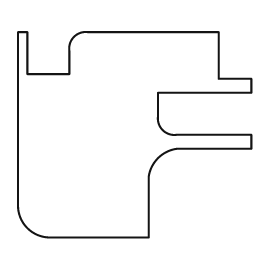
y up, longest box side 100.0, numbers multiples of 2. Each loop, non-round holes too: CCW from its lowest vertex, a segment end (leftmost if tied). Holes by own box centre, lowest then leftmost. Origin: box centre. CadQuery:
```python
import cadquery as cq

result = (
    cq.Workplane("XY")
    .moveTo(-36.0, -44.0)
    .lineTo(6.0, -44.0)
    .lineTo(6.0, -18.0)
    .threePointArc((10.0, -10.0), (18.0, -6.0))
    .lineTo(50.0, -6.0)
    .lineTo(50.0, 0.0)
    .lineTo(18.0, 0.0)
    .threePointArc((12.0, 2.0), (10.0, 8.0))
    .lineTo(10.0, 18.0)
    .lineTo(50.0, 18.0)
    .lineTo(50.0, 24.0)
    .lineTo(36.0, 24.0)
    .lineTo(36.0, 44.0)
    .lineTo(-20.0, 44.0)
    .threePointArc((-26.0, 42.0), (-28.0, 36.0))
    .lineTo(-28.0, 26.0)
    .lineTo(-46.0, 26.0)
    .lineTo(-46.0, 44.0)
    .lineTo(-50.0, 44.0)
    .lineTo(-50.0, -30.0)
    .threePointArc((-46.0, -40.0), (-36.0, -44.0))
    .close()
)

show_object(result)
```